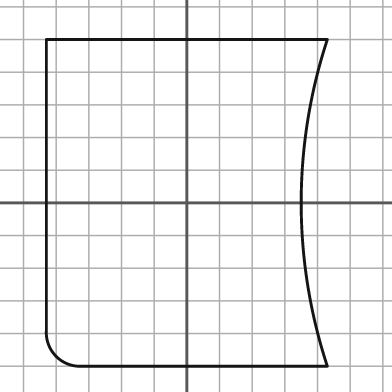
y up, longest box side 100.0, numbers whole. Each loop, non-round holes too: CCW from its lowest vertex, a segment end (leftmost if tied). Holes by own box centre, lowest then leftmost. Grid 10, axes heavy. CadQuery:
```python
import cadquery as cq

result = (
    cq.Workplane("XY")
    .moveTo(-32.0, -50.0)
    .lineTo(43.0, -50.0)
    .threePointArc((35.0, 0.0), (43.0, 50.0))
    .lineTo(-43.0, 50.0)
    .lineTo(-43.0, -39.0)
    .threePointArc((-40.0, -47.0), (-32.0, -50.0))
    .close()
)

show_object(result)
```